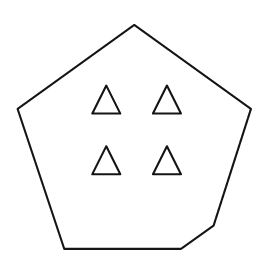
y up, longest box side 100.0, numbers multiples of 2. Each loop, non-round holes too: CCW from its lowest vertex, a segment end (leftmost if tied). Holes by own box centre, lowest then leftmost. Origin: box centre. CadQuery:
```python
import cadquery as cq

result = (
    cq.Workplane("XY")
    .moveTo(-30.0, -48.0)
    .lineTo(20.0, -48.0)
    .lineTo(34.0, -38.0)
    .lineTo(50.0, 12.0)
    .lineTo(0.0, 48.0)
    .lineTo(-50.0, 12.0)
    .close()
    .moveTo(-18.0, -16.0)
    .lineTo(-6.0, -16.0)
    .lineTo(-12.0, -4.0)
    .close()
    .moveTo(8.0, -16.0)
    .lineTo(20.0, -16.0)
    .lineTo(14.0, -4.0)
    .close()
    .moveTo(-18.0, 10.0)
    .lineTo(-6.0, 10.0)
    .lineTo(-12.0, 22.0)
    .close()
    .moveTo(8.0, 10.0)
    .lineTo(20.0, 10.0)
    .lineTo(14.0, 22.0)
    .close()
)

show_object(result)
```